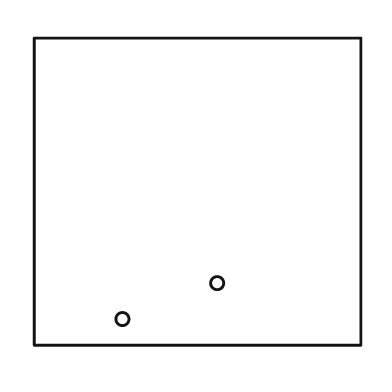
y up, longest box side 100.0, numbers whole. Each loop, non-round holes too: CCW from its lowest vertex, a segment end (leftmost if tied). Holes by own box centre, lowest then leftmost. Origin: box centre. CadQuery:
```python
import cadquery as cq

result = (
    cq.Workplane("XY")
    .moveTo(-50.0, -47.0)
    .lineTo(50.0, -47.0)
    .lineTo(50.0, 47.0)
    .lineTo(-50.0, 47.0)
    .close()
    .moveTo(-23.0, -39.0)
    .circle(2.0)
    .moveTo(6.0, -28.0)
    .circle(2.0)
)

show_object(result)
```